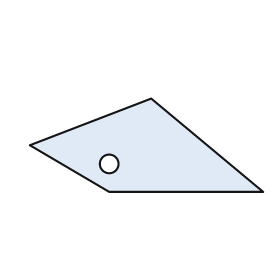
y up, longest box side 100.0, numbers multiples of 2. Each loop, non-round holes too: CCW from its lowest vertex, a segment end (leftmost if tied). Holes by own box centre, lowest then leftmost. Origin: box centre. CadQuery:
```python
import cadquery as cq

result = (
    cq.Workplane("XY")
    .moveTo(-16.0, -20.0)
    .lineTo(50.0, -20.0)
    .lineTo(2.0, 20.0)
    .lineTo(-50.0, 0.0)
    .close()
    .moveTo(-16.0, -8.0)
    .circle(4.0)
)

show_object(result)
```